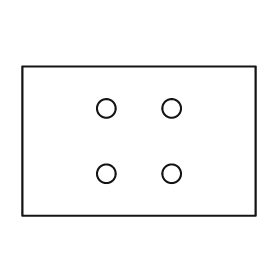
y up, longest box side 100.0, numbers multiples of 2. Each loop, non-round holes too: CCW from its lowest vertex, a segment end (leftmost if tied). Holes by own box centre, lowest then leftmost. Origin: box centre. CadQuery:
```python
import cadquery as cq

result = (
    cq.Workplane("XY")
    .moveTo(-50.0, -32.0)
    .lineTo(50.0, -32.0)
    .lineTo(50.0, 32.0)
    .lineTo(-50.0, 32.0)
    .close()
    .moveTo(-14.0, -14.0)
    .circle(4.0)
    .moveTo(14.0, -14.0)
    .circle(4.0)
    .moveTo(-14.0, 14.0)
    .circle(4.0)
    .moveTo(14.0, 14.0)
    .circle(4.0)
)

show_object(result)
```